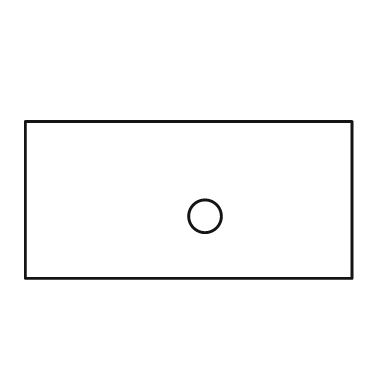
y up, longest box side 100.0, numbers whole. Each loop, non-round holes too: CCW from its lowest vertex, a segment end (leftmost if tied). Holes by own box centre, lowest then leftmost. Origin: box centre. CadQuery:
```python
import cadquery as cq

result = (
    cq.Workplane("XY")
    .moveTo(-50.0, -24.0)
    .lineTo(50.0, -24.0)
    .lineTo(50.0, 24.0)
    .lineTo(-50.0, 24.0)
    .close()
    .moveTo(5.0, -5.0)
    .circle(5.0)
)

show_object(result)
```